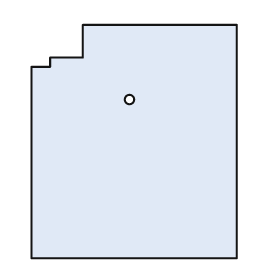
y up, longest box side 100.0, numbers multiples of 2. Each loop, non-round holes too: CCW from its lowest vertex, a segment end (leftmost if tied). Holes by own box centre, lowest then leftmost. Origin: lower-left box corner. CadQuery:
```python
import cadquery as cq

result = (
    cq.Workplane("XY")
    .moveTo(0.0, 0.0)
    .lineTo(88.0, 0.0)
    .lineTo(88.0, 100.0)
    .lineTo(22.0, 100.0)
    .lineTo(22.0, 86.0)
    .lineTo(8.0, 86.0)
    .lineTo(8.0, 82.0)
    .lineTo(0.0, 82.0)
    .close()
    .moveTo(42.0, 68.0)
    .circle(2.0)
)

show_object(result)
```